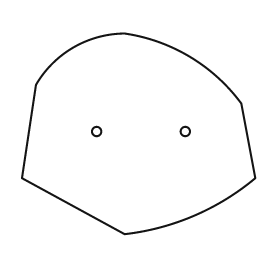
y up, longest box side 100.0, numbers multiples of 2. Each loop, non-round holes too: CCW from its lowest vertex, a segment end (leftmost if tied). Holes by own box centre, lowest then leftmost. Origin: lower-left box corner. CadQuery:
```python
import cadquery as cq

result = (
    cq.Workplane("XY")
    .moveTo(44.0, 0.0)
    .threePointArc((74.0, 8.0), (100.0, 24.0))
    .lineTo(94.0, 56.0)
    .threePointArc((72.0, 76.0), (44.0, 86.0))
    .threePointArc((22.0, 80.0), (6.0, 64.0))
    .lineTo(0.0, 24.0)
    .close()
    .moveTo(32.0, 44.0)
    .circle(2.0)
    .moveTo(70.0, 44.0)
    .circle(2.0)
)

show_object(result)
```